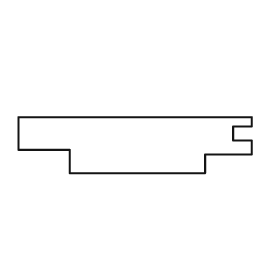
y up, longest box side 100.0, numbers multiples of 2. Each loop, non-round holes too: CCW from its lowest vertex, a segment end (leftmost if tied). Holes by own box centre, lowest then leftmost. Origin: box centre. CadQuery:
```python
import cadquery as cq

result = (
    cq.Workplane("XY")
    .moveTo(-28.0, -12.0)
    .lineTo(30.0, -12.0)
    .lineTo(30.0, -4.0)
    .lineTo(50.0, -4.0)
    .lineTo(50.0, 2.0)
    .lineTo(42.0, 2.0)
    .lineTo(42.0, 8.0)
    .lineTo(50.0, 8.0)
    .lineTo(50.0, 12.0)
    .lineTo(-50.0, 12.0)
    .lineTo(-50.0, -2.0)
    .lineTo(-28.0, -2.0)
    .close()
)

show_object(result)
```